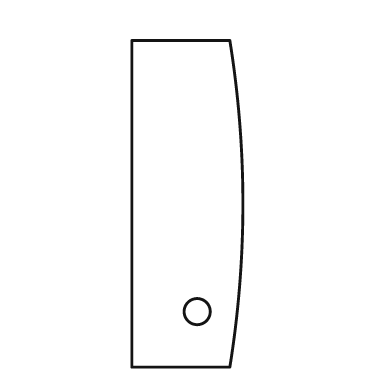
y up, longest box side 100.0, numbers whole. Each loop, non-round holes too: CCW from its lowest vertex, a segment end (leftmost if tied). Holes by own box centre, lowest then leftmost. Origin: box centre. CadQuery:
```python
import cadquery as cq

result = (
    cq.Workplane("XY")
    .moveTo(-17.0, -50.0)
    .lineTo(13.0, -50.0)
    .threePointArc((17.0, 0.0), (13.0, 50.0))
    .lineTo(-17.0, 50.0)
    .close()
    .moveTo(3.0, -33.0)
    .circle(4.0)
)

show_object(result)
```